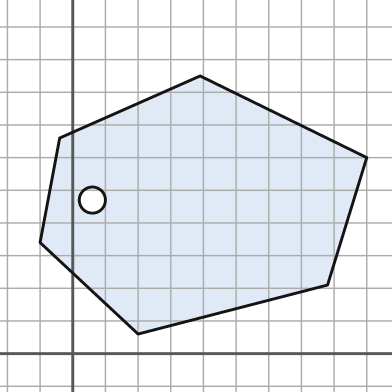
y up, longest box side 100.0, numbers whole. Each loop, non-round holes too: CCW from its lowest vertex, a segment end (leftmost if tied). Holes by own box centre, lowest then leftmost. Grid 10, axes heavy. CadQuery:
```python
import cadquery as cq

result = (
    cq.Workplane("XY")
    .moveTo(20.0, 6.0)
    .lineTo(78.0, 21.0)
    .lineTo(90.0, 60.0)
    .lineTo(39.0, 85.0)
    .lineTo(-4.0, 66.0)
    .lineTo(-10.0, 34.0)
    .close()
    .moveTo(6.0, 47.0)
    .circle(4.0)
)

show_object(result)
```